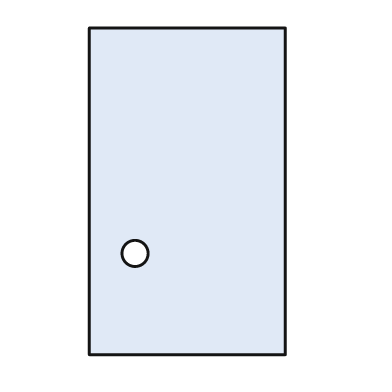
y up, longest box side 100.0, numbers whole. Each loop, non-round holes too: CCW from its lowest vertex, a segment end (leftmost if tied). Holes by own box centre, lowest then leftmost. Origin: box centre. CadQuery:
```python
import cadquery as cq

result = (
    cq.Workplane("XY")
    .moveTo(-30.0, -50.0)
    .lineTo(30.0, -50.0)
    .lineTo(30.0, 50.0)
    .lineTo(-30.0, 50.0)
    .close()
    .moveTo(-16.0, -19.0)
    .circle(4.0)
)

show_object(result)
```